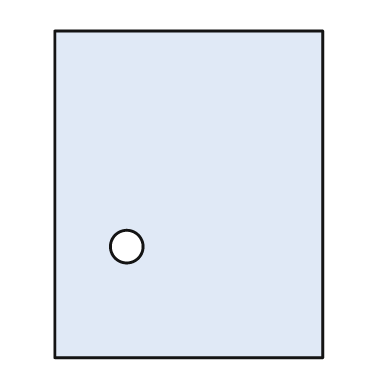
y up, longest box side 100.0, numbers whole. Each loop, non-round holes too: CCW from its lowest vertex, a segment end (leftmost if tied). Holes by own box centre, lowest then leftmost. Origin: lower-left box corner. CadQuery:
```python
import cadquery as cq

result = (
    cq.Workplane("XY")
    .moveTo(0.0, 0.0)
    .lineTo(82.0, 0.0)
    .lineTo(82.0, 100.0)
    .lineTo(0.0, 100.0)
    .close()
    .moveTo(22.0, 34.0)
    .circle(5.0)
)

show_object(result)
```